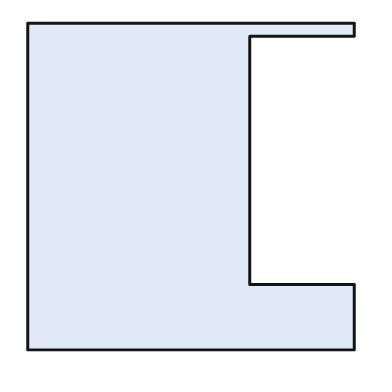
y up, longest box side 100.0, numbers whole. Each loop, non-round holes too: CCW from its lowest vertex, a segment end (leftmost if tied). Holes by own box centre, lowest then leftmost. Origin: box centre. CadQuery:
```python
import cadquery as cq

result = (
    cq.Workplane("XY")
    .moveTo(-50.0, -50.0)
    .lineTo(50.0, -50.0)
    .lineTo(50.0, -30.0)
    .lineTo(18.0, -30.0)
    .lineTo(18.0, 46.0)
    .lineTo(50.0, 46.0)
    .lineTo(50.0, 50.0)
    .lineTo(-50.0, 50.0)
    .close()
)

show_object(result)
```